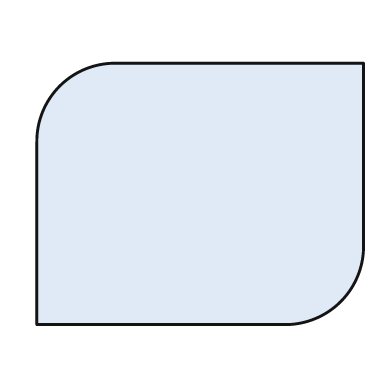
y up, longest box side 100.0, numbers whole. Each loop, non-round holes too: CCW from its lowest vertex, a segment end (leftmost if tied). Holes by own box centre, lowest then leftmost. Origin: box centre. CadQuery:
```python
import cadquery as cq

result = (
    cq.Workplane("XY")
    .moveTo(-50.0, -40.0)
    .lineTo(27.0, -40.0)
    .threePointArc((43.0, -33.0), (50.0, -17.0))
    .lineTo(50.0, 40.0)
    .lineTo(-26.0, 40.0)
    .threePointArc((-43.0, 33.0), (-50.0, 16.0))
    .close()
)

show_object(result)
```